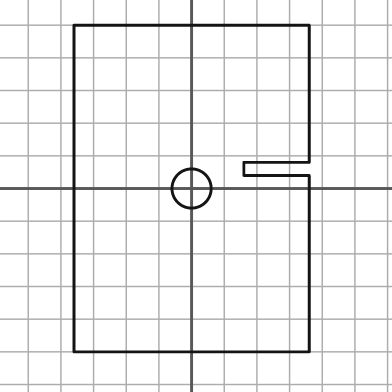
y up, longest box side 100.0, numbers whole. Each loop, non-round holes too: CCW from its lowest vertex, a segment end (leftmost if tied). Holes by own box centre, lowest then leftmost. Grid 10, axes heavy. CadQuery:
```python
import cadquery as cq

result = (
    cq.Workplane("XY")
    .moveTo(-36.0, -50.0)
    .lineTo(36.0, -50.0)
    .lineTo(36.0, 4.0)
    .lineTo(16.0, 4.0)
    .lineTo(16.0, 8.0)
    .lineTo(36.0, 8.0)
    .lineTo(36.0, 50.0)
    .lineTo(-36.0, 50.0)
    .close()
    .moveTo(0.0, 0.0)
    .circle(6.0)
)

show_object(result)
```